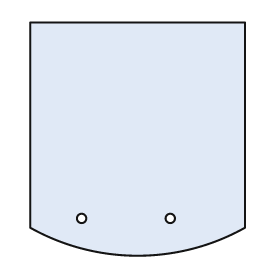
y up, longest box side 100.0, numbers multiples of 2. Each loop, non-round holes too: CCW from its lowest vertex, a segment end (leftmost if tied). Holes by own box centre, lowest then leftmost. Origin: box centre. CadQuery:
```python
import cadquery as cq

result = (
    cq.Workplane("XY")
    .moveTo(-46.0, -38.0)
    .threePointArc((0.0, -50.0), (46.0, -38.0))
    .lineTo(46.0, 50.0)
    .lineTo(-46.0, 50.0)
    .close()
    .moveTo(-24.0, -34.0)
    .circle(2.0)
    .moveTo(14.0, -34.0)
    .circle(2.0)
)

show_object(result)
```